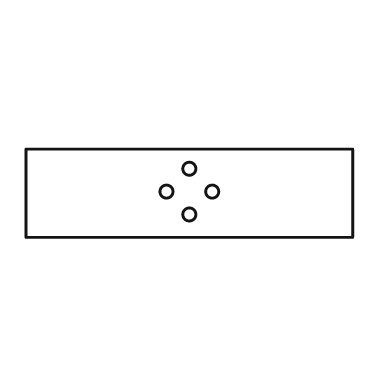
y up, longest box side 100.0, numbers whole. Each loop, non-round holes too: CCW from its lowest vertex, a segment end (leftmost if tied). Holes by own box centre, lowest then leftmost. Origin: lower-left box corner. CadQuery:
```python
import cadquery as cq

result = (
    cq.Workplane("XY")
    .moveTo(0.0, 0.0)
    .lineTo(100.0, 0.0)
    .lineTo(100.0, 27.0)
    .lineTo(0.0, 27.0)
    .close()
    .moveTo(50.0, 7.0)
    .circle(2.0)
    .moveTo(43.0, 14.0)
    .circle(2.0)
    .moveTo(57.0, 14.0)
    .circle(2.0)
    .moveTo(50.0, 21.0)
    .circle(2.0)
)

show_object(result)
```